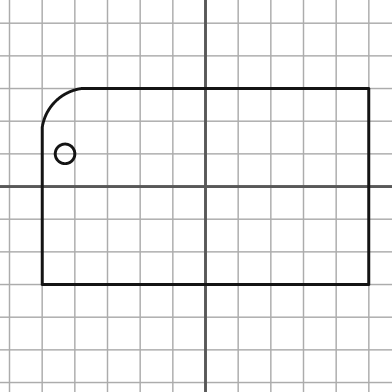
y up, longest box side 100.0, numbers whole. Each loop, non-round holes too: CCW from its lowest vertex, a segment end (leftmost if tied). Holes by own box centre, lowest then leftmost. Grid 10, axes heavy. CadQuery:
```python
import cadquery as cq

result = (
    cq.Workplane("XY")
    .moveTo(-50.0, -30.0)
    .lineTo(50.0, -30.0)
    .lineTo(50.0, 30.0)
    .lineTo(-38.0, 30.0)
    .threePointArc((-46.0, 26.0), (-50.0, 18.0))
    .close()
    .moveTo(-43.0, 10.0)
    .circle(3.0)
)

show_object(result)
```